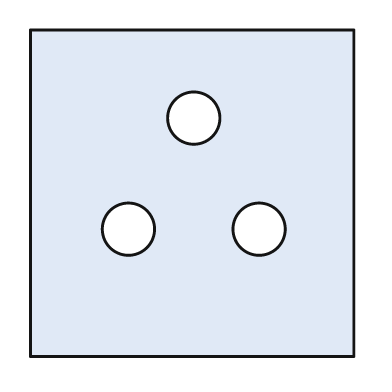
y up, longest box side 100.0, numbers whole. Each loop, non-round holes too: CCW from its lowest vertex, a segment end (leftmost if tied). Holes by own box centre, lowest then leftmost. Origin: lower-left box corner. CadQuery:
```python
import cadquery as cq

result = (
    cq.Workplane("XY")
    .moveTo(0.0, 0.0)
    .lineTo(99.0, 0.0)
    .lineTo(99.0, 100.0)
    .lineTo(0.0, 100.0)
    .close()
    .moveTo(30.0, 39.0)
    .circle(8.0)
    .moveTo(70.0, 39.0)
    .circle(8.0)
    .moveTo(50.0, 73.0)
    .circle(8.0)
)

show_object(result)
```